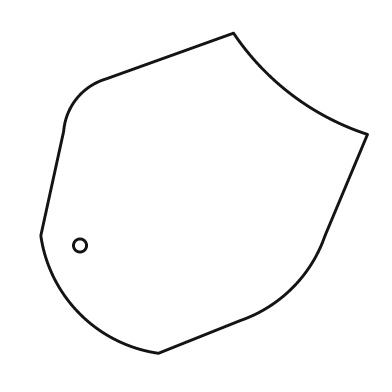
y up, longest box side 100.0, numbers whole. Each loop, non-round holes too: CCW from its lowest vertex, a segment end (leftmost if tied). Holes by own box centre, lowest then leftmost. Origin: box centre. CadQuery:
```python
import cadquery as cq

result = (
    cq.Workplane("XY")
    .moveTo(-14.0, -49.0)
    .lineTo(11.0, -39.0)
    .threePointArc((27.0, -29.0), (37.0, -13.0))
    .lineTo(50.0, 18.0)
    .threePointArc((27.0, 30.0), (9.0, 49.0))
    .lineTo(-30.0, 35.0)
    .threePointArc((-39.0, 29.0), (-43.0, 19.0))
    .lineTo(-50.0, -13.0)
    .threePointArc((-38.0, -37.0), (-14.0, -49.0))
    .close()
    .moveTo(-38.0, -16.0)
    .circle(2.0)
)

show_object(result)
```